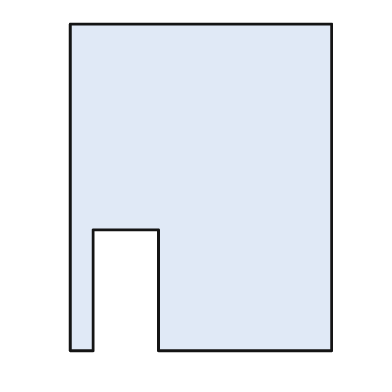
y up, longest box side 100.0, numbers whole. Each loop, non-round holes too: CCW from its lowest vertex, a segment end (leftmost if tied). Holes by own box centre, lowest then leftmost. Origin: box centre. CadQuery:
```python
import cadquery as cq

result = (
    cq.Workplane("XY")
    .moveTo(-40.0, -50.0)
    .lineTo(-33.0, -50.0)
    .lineTo(-33.0, -13.0)
    .lineTo(-13.0, -13.0)
    .lineTo(-13.0, -50.0)
    .lineTo(40.0, -50.0)
    .lineTo(40.0, 50.0)
    .lineTo(-40.0, 50.0)
    .close()
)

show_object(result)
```